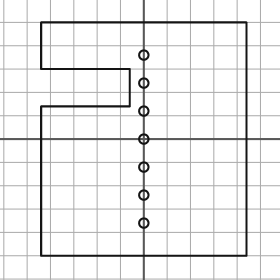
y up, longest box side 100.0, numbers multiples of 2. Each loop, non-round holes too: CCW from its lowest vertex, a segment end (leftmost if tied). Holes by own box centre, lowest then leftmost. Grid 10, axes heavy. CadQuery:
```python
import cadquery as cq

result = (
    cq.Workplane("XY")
    .moveTo(-44.0, -50.0)
    .lineTo(44.0, -50.0)
    .lineTo(44.0, 50.0)
    .lineTo(-44.0, 50.0)
    .lineTo(-44.0, 30.0)
    .lineTo(-6.0, 30.0)
    .lineTo(-6.0, 14.0)
    .lineTo(-44.0, 14.0)
    .close()
    .moveTo(0.0, -36.0)
    .circle(2.0)
    .moveTo(0.0, -24.0)
    .circle(2.0)
    .moveTo(0.0, -12.0)
    .circle(2.0)
    .moveTo(0.0, 0.0)
    .circle(2.0)
    .moveTo(0.0, 12.0)
    .circle(2.0)
    .moveTo(0.0, 24.0)
    .circle(2.0)
    .moveTo(0.0, 36.0)
    .circle(2.0)
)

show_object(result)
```